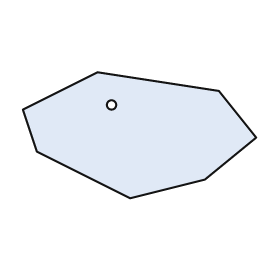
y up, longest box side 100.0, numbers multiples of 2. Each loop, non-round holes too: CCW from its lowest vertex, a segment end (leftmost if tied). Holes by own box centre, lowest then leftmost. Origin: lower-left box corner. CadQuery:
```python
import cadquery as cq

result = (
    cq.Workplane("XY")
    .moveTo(46.0, 0.0)
    .lineTo(78.0, 8.0)
    .lineTo(100.0, 26.0)
    .lineTo(84.0, 46.0)
    .lineTo(32.0, 54.0)
    .lineTo(0.0, 38.0)
    .lineTo(6.0, 20.0)
    .close()
    .moveTo(38.0, 40.0)
    .circle(2.0)
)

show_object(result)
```